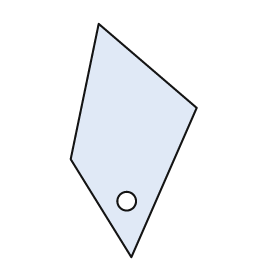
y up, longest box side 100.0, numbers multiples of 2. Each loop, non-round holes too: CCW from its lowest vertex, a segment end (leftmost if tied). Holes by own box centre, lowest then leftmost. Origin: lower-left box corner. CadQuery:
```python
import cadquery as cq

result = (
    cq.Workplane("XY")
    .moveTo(26.0, 0.0)
    .lineTo(54.0, 64.0)
    .lineTo(12.0, 100.0)
    .lineTo(0.0, 42.0)
    .close()
    .moveTo(24.0, 24.0)
    .circle(4.0)
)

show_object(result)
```